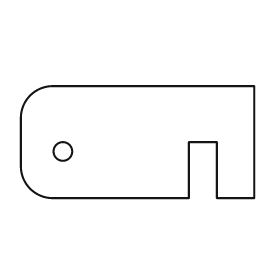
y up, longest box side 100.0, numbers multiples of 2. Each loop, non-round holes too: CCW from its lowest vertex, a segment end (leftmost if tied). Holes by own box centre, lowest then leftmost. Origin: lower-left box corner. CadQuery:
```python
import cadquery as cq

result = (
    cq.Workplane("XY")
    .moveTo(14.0, 0.0)
    .lineTo(72.0, 0.0)
    .lineTo(72.0, 24.0)
    .lineTo(84.0, 24.0)
    .lineTo(84.0, 0.0)
    .lineTo(100.0, 0.0)
    .lineTo(100.0, 48.0)
    .lineTo(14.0, 48.0)
    .threePointArc((4.0, 44.0), (0.0, 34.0))
    .lineTo(0.0, 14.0)
    .threePointArc((4.0, 4.0), (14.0, 0.0))
    .close()
    .moveTo(18.0, 20.0)
    .circle(4.0)
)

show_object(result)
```